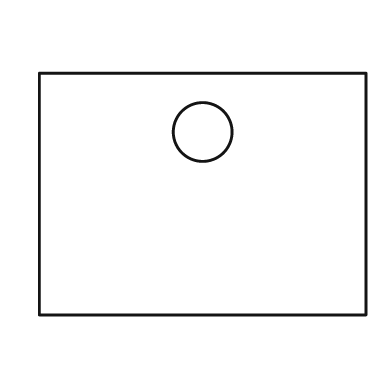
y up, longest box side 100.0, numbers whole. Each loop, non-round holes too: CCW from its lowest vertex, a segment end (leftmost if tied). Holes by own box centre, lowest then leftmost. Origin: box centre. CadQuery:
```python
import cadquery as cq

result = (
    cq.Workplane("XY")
    .moveTo(-50.0, -37.0)
    .lineTo(50.0, -37.0)
    .lineTo(50.0, 37.0)
    .lineTo(-50.0, 37.0)
    .close()
    .moveTo(0.0, 19.0)
    .circle(9.0)
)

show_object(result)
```